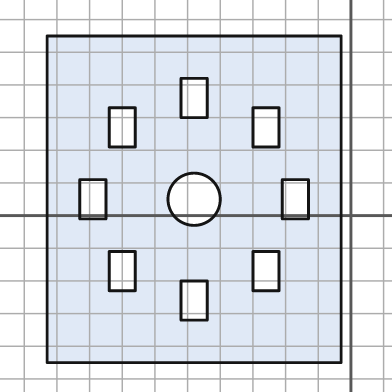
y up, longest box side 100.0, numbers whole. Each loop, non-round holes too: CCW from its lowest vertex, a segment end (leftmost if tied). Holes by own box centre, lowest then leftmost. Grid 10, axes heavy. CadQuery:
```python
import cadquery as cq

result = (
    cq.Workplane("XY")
    .moveTo(-93.0, -45.0)
    .lineTo(-3.0, -45.0)
    .lineTo(-3.0, 55.0)
    .lineTo(-93.0, 55.0)
    .close()
    .moveTo(-52.0, -32.0)
    .lineTo(-44.0, -32.0)
    .lineTo(-44.0, -20.0)
    .lineTo(-52.0, -20.0)
    .close()
    .moveTo(-74.0, -23.0)
    .lineTo(-66.0, -23.0)
    .lineTo(-66.0, -11.0)
    .lineTo(-74.0, -11.0)
    .close()
    .moveTo(-30.0, -23.0)
    .lineTo(-22.0, -23.0)
    .lineTo(-22.0, -11.0)
    .lineTo(-30.0, -11.0)
    .close()
    .moveTo(-83.0, -1.0)
    .lineTo(-75.0, -1.0)
    .lineTo(-75.0, 11.0)
    .lineTo(-83.0, 11.0)
    .close()
    .moveTo(-48.0, 5.0)
    .circle(8.0)
    .moveTo(-21.0, -1.0)
    .lineTo(-13.0, -1.0)
    .lineTo(-13.0, 11.0)
    .lineTo(-21.0, 11.0)
    .close()
    .moveTo(-74.0, 21.0)
    .lineTo(-66.0, 21.0)
    .lineTo(-66.0, 33.0)
    .lineTo(-74.0, 33.0)
    .close()
    .moveTo(-30.0, 21.0)
    .lineTo(-22.0, 21.0)
    .lineTo(-22.0, 33.0)
    .lineTo(-30.0, 33.0)
    .close()
    .moveTo(-52.0, 30.0)
    .lineTo(-44.0, 30.0)
    .lineTo(-44.0, 42.0)
    .lineTo(-52.0, 42.0)
    .close()
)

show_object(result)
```